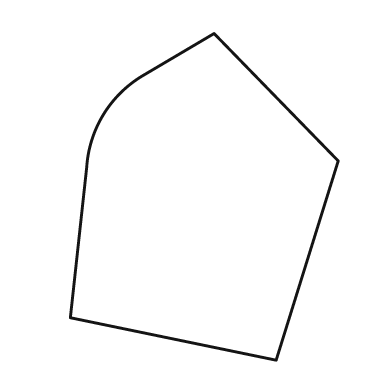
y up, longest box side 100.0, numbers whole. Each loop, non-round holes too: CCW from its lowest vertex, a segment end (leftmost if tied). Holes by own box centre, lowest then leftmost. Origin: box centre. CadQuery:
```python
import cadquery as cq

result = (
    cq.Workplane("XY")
    .moveTo(22.0, -50.0)
    .lineTo(41.0, 11.0)
    .lineTo(3.0, 50.0)
    .lineTo(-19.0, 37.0)
    .threePointArc((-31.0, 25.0), (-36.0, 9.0))
    .lineTo(-41.0, -37.0)
    .close()
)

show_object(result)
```